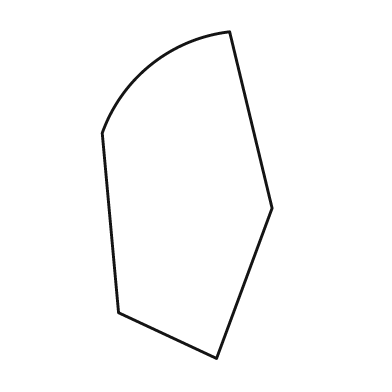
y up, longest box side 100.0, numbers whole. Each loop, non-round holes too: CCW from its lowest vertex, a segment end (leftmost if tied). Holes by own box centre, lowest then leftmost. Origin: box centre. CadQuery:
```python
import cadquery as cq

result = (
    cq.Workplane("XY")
    .moveTo(9.0, -50.0)
    .lineTo(26.0, -4.0)
    .lineTo(13.0, 50.0)
    .threePointArc((-11.0, 40.0), (-26.0, 19.0))
    .lineTo(-21.0, -36.0)
    .close()
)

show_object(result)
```